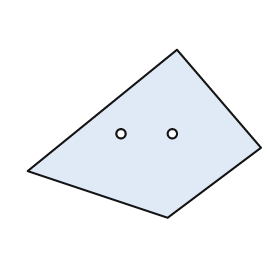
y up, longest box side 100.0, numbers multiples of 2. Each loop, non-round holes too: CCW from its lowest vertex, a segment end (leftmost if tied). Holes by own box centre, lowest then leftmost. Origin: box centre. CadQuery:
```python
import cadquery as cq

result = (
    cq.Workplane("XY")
    .moveTo(10.0, -36.0)
    .lineTo(50.0, -6.0)
    .lineTo(14.0, 36.0)
    .lineTo(-50.0, -16.0)
    .close()
    .moveTo(-10.0, 0.0)
    .circle(2.0)
    .moveTo(12.0, 0.0)
    .circle(2.0)
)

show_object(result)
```